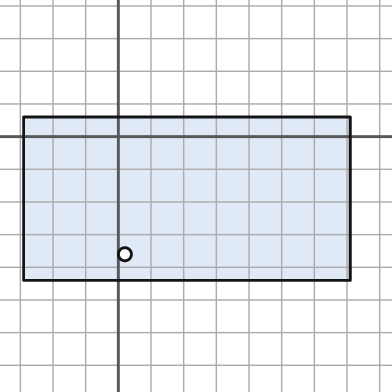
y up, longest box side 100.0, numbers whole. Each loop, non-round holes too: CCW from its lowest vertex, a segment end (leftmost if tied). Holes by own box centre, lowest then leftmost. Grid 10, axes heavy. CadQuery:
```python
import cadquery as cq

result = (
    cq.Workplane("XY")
    .moveTo(-29.0, -44.0)
    .lineTo(71.0, -44.0)
    .lineTo(71.0, 6.0)
    .lineTo(-29.0, 6.0)
    .close()
    .moveTo(2.0, -36.0)
    .circle(2.0)
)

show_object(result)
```